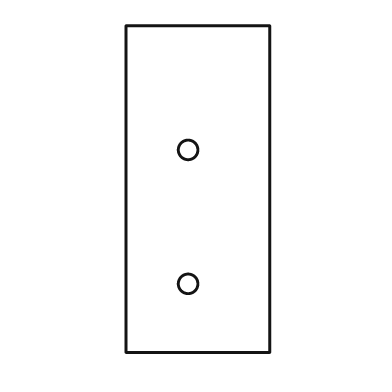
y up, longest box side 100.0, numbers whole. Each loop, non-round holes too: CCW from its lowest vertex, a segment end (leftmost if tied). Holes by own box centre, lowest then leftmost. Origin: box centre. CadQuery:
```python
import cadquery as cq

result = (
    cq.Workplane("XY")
    .moveTo(-22.0, -50.0)
    .lineTo(22.0, -50.0)
    .lineTo(22.0, 50.0)
    .lineTo(-22.0, 50.0)
    .close()
    .moveTo(-3.0, -29.0)
    .circle(3.0)
    .moveTo(-3.0, 12.0)
    .circle(3.0)
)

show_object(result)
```